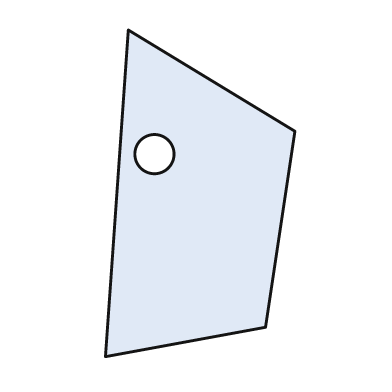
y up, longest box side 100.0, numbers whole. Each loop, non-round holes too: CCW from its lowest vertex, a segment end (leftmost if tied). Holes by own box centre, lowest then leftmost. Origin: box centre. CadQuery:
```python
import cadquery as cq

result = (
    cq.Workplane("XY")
    .moveTo(-29.0, -50.0)
    .lineTo(20.0, -41.0)
    .lineTo(29.0, 19.0)
    .lineTo(-22.0, 50.0)
    .close()
    .moveTo(-14.0, 12.0)
    .circle(6.0)
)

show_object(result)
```